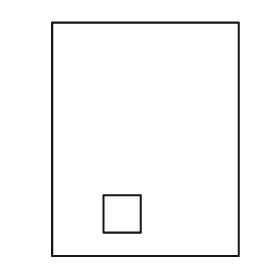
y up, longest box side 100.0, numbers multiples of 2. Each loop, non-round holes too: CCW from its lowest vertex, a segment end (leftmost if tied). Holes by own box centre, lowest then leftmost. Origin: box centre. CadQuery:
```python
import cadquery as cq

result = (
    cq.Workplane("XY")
    .moveTo(-40.0, -50.0)
    .lineTo(40.0, -50.0)
    .lineTo(40.0, 50.0)
    .lineTo(-40.0, 50.0)
    .close()
    .moveTo(-18.0, -40.0)
    .lineTo(-2.0, -40.0)
    .lineTo(-2.0, -24.0)
    .lineTo(-18.0, -24.0)
    .close()
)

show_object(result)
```